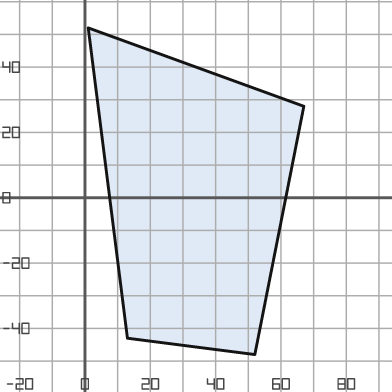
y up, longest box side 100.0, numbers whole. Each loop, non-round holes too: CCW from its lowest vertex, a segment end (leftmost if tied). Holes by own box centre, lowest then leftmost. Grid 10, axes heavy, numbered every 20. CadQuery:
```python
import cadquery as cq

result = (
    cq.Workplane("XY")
    .moveTo(52.0, -48.0)
    .lineTo(67.0, 28.0)
    .lineTo(1.0, 52.0)
    .lineTo(13.0, -43.0)
    .close()
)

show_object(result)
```